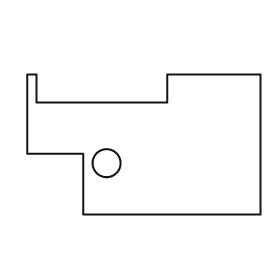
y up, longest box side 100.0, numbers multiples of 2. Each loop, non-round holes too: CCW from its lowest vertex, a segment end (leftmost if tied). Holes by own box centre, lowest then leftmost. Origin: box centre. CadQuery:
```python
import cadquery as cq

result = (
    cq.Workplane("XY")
    .moveTo(-26.0, -30.0)
    .lineTo(50.0, -30.0)
    .lineTo(50.0, 30.0)
    .lineTo(10.0, 30.0)
    .lineTo(10.0, 18.0)
    .lineTo(-46.0, 18.0)
    .lineTo(-46.0, 30.0)
    .lineTo(-50.0, 30.0)
    .lineTo(-50.0, -4.0)
    .lineTo(-26.0, -4.0)
    .close()
    .moveTo(-16.0, -8.0)
    .circle(6.0)
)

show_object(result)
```